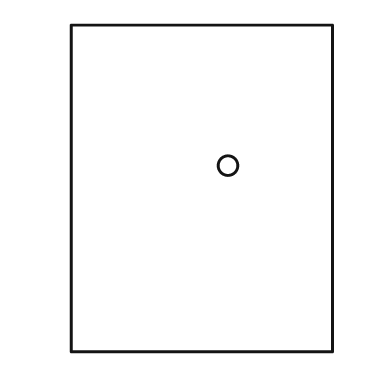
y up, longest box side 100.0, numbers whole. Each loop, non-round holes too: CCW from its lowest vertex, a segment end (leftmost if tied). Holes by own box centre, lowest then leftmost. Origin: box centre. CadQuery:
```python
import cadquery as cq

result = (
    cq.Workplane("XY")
    .moveTo(-40.0, -50.0)
    .lineTo(40.0, -50.0)
    .lineTo(40.0, 50.0)
    .lineTo(-40.0, 50.0)
    .close()
    .moveTo(8.0, 7.0)
    .circle(3.0)
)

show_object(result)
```